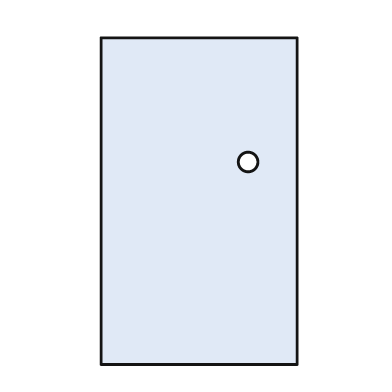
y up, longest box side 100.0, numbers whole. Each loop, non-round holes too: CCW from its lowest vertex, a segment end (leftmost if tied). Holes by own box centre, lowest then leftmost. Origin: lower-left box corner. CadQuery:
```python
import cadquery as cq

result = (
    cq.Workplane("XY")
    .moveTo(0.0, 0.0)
    .lineTo(60.0, 0.0)
    .lineTo(60.0, 100.0)
    .lineTo(0.0, 100.0)
    .close()
    .moveTo(45.0, 62.0)
    .circle(3.0)
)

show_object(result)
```